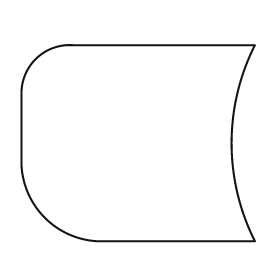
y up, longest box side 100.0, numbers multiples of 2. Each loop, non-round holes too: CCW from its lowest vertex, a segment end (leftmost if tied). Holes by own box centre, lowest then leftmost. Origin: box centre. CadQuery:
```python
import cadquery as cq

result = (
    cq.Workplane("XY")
    .moveTo(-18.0, -42.0)
    .lineTo(50.0, -42.0)
    .threePointArc((40.0, 0.0), (50.0, 42.0))
    .lineTo(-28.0, 42.0)
    .threePointArc((-44.0, 36.0), (-50.0, 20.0))
    .lineTo(-50.0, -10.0)
    .threePointArc((-40.0, -32.0), (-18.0, -42.0))
    .close()
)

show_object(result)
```